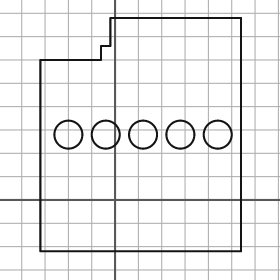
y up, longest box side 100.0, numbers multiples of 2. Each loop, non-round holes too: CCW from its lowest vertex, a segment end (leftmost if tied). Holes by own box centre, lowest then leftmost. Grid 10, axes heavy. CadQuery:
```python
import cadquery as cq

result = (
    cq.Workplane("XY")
    .moveTo(-32.0, -22.0)
    .lineTo(54.0, -22.0)
    .lineTo(54.0, 78.0)
    .lineTo(-2.0, 78.0)
    .lineTo(-2.0, 66.0)
    .lineTo(-6.0, 66.0)
    .lineTo(-6.0, 60.0)
    .lineTo(-32.0, 60.0)
    .close()
    .moveTo(-20.0, 28.0)
    .circle(6.0)
    .moveTo(-4.0, 28.0)
    .circle(6.0)
    .moveTo(12.0, 28.0)
    .circle(6.0)
    .moveTo(28.0, 28.0)
    .circle(6.0)
    .moveTo(44.0, 28.0)
    .circle(6.0)
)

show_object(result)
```